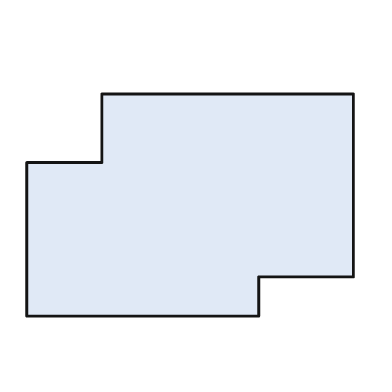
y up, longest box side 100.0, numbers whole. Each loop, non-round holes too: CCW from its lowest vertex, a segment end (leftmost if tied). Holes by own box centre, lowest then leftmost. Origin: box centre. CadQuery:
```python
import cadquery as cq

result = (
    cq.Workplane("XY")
    .moveTo(-50.0, -34.0)
    .lineTo(21.0, -34.0)
    .lineTo(21.0, -22.0)
    .lineTo(50.0, -22.0)
    .lineTo(50.0, 34.0)
    .lineTo(-27.0, 34.0)
    .lineTo(-27.0, 13.0)
    .lineTo(-50.0, 13.0)
    .close()
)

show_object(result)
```